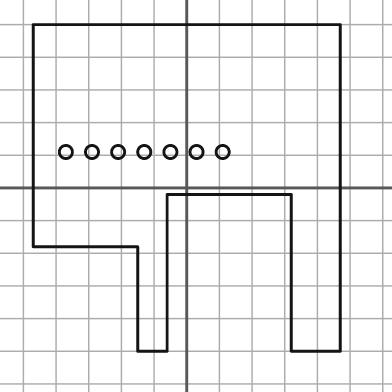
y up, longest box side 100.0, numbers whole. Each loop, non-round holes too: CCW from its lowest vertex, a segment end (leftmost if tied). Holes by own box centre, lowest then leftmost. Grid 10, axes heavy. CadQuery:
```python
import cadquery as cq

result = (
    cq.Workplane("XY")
    .moveTo(-15.0, -50.0)
    .lineTo(-6.0, -50.0)
    .lineTo(-6.0, -2.0)
    .lineTo(32.0, -2.0)
    .lineTo(32.0, -50.0)
    .lineTo(47.0, -50.0)
    .lineTo(47.0, 50.0)
    .lineTo(-47.0, 50.0)
    .lineTo(-47.0, -18.0)
    .lineTo(-15.0, -18.0)
    .close()
    .moveTo(-37.0, 11.0)
    .circle(2.0)
    .moveTo(-29.0, 11.0)
    .circle(2.0)
    .moveTo(-21.0, 11.0)
    .circle(2.0)
    .moveTo(-13.0, 11.0)
    .circle(2.0)
    .moveTo(-5.0, 11.0)
    .circle(2.0)
    .moveTo(3.0, 11.0)
    .circle(2.0)
    .moveTo(11.0, 11.0)
    .circle(2.0)
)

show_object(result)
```